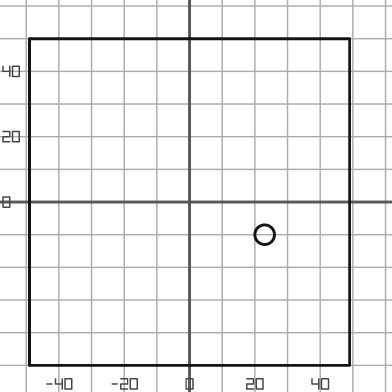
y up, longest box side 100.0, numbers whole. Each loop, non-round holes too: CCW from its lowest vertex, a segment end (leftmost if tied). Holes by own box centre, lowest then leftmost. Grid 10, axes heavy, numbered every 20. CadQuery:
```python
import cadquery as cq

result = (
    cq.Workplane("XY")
    .moveTo(-49.0, -50.0)
    .lineTo(49.0, -50.0)
    .lineTo(49.0, 50.0)
    .lineTo(-49.0, 50.0)
    .close()
    .moveTo(23.0, -10.0)
    .circle(3.0)
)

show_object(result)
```